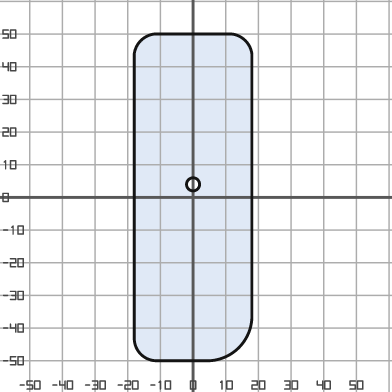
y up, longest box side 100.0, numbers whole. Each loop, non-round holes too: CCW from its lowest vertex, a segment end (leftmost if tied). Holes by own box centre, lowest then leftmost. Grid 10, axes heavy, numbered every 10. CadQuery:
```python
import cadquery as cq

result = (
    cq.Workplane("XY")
    .moveTo(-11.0, -50.0)
    .lineTo(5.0, -50.0)
    .threePointArc((14.0, -46.0), (18.0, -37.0))
    .lineTo(18.0, 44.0)
    .threePointArc((16.0, 48.0), (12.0, 50.0))
    .lineTo(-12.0, 50.0)
    .threePointArc((-16.0, 48.0), (-18.0, 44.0))
    .lineTo(-18.0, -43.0)
    .threePointArc((-16.0, -48.0), (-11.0, -50.0))
    .close()
    .moveTo(0.0, 4.0)
    .circle(2.0)
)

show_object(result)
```